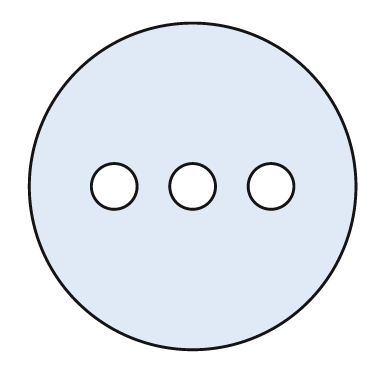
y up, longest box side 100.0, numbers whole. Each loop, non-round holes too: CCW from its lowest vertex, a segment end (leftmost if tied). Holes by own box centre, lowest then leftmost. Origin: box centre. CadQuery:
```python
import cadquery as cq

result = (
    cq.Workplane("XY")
    .moveTo(0.0, 0.0)
    .circle(50.0)
    .moveTo(-24.0, 0.0)
    .circle(7.0)
    .moveTo(0.0, 0.0)
    .circle(7.0)
    .moveTo(24.0, 0.0)
    .circle(7.0)
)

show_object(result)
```